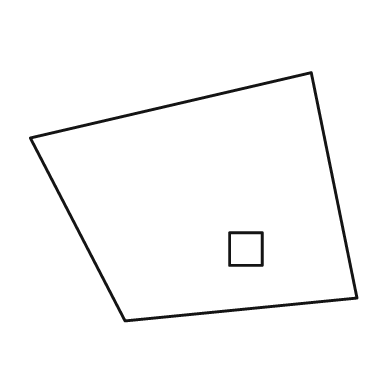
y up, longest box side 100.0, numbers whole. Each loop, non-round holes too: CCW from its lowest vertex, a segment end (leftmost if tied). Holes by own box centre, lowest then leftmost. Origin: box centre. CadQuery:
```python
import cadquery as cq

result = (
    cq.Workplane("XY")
    .moveTo(-21.0, -38.0)
    .lineTo(50.0, -31.0)
    .lineTo(36.0, 38.0)
    .lineTo(-50.0, 18.0)
    .close()
    .moveTo(11.0, -21.0)
    .lineTo(21.0, -21.0)
    .lineTo(21.0, -11.0)
    .lineTo(11.0, -11.0)
    .close()
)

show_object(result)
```